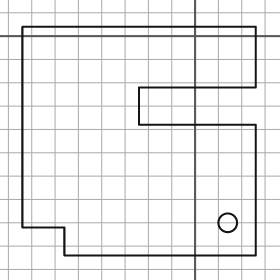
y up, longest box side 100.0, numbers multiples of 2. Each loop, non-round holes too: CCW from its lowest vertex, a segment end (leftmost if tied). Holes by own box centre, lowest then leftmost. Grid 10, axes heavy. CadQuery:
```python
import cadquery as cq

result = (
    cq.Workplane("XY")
    .moveTo(-56.0, -94.0)
    .lineTo(26.0, -94.0)
    .lineTo(26.0, -38.0)
    .lineTo(-24.0, -38.0)
    .lineTo(-24.0, -22.0)
    .lineTo(26.0, -22.0)
    .lineTo(26.0, 4.0)
    .lineTo(-74.0, 4.0)
    .lineTo(-74.0, -82.0)
    .lineTo(-56.0, -82.0)
    .close()
    .moveTo(14.0, -80.0)
    .circle(4.0)
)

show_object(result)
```